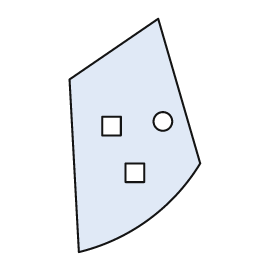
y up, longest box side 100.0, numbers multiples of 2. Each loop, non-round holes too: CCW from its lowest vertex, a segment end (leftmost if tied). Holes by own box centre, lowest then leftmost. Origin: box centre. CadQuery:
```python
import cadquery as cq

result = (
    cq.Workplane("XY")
    .moveTo(-24.0, -50.0)
    .threePointArc((6.0, -36.0), (28.0, -12.0))
    .lineTo(10.0, 50.0)
    .lineTo(-28.0, 24.0)
    .close()
    .moveTo(-4.0, -20.0)
    .lineTo(4.0, -20.0)
    .lineTo(4.0, -12.0)
    .lineTo(-4.0, -12.0)
    .close()
    .moveTo(-14.0, 0.0)
    .lineTo(-6.0, 0.0)
    .lineTo(-6.0, 8.0)
    .lineTo(-14.0, 8.0)
    .close()
    .moveTo(12.0, 6.0)
    .circle(4.0)
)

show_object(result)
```